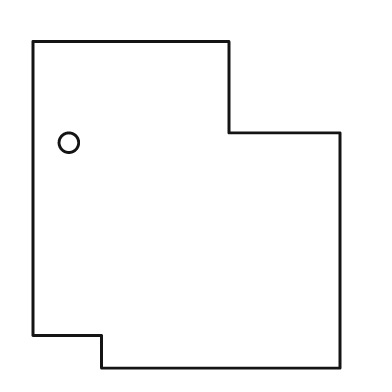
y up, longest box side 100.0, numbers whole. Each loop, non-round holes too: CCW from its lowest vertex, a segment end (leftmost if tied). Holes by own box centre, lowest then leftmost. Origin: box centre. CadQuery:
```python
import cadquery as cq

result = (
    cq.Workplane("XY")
    .moveTo(-26.0, -50.0)
    .lineTo(47.0, -50.0)
    .lineTo(47.0, 22.0)
    .lineTo(13.0, 22.0)
    .lineTo(13.0, 50.0)
    .lineTo(-47.0, 50.0)
    .lineTo(-47.0, -40.0)
    .lineTo(-26.0, -40.0)
    .close()
    .moveTo(-36.0, 19.0)
    .circle(3.0)
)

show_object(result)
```